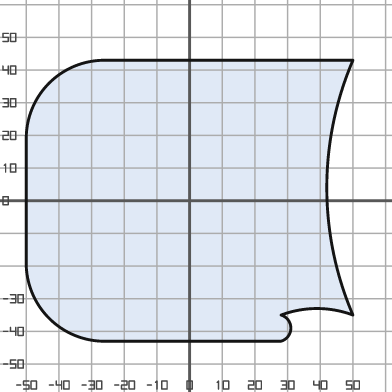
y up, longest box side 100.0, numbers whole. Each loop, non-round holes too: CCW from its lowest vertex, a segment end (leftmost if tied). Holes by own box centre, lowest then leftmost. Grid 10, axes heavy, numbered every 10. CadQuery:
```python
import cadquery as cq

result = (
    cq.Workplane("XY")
    .moveTo(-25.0, -43.0)
    .lineTo(28.0, -43.0)
    .threePointArc((31.0, -39.0), (28.0, -35.0))
    .threePointArc((39.0, -33.0), (50.0, -35.0))
    .threePointArc((42.0, 4.0), (50.0, 43.0))
    .lineTo(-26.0, 43.0)
    .threePointArc((-43.0, 36.0), (-50.0, 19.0))
    .lineTo(-50.0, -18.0)
    .threePointArc((-43.0, -36.0), (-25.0, -43.0))
    .close()
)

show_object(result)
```